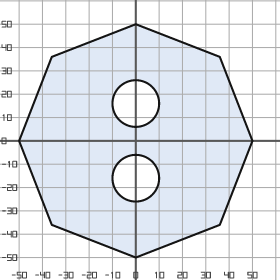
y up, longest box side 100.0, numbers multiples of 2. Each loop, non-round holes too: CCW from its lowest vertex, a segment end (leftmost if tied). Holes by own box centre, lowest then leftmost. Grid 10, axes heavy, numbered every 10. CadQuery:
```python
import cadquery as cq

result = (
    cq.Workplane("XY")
    .moveTo(0.0, -50.0)
    .lineTo(36.0, -36.0)
    .lineTo(50.0, 0.0)
    .lineTo(36.0, 36.0)
    .lineTo(0.0, 50.0)
    .lineTo(-36.0, 36.0)
    .lineTo(-50.0, 0.0)
    .lineTo(-36.0, -36.0)
    .close()
    .moveTo(0.0, -16.0)
    .circle(10.0)
    .moveTo(0.0, 16.0)
    .circle(10.0)
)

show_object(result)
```